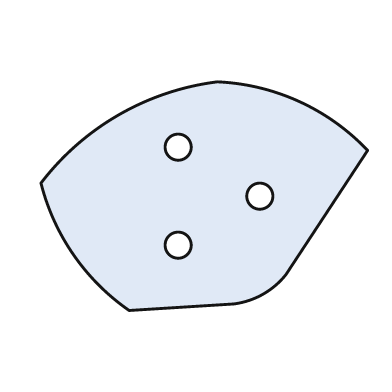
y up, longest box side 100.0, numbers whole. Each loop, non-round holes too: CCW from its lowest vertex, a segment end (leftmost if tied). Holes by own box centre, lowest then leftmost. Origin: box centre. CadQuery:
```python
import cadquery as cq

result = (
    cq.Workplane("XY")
    .moveTo(-23.0, -35.0)
    .lineTo(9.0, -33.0)
    .threePointArc((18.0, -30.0), (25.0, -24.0))
    .lineTo(50.0, 14.0)
    .threePointArc((29.0, 29.0), (4.0, 35.0))
    .threePointArc((-26.0, 25.0), (-50.0, 4.0))
    .threePointArc((-40.0, -18.0), (-23.0, -35.0))
    .close()
    .moveTo(-8.0, -15.0)
    .circle(4.0)
    .moveTo(17.0, 0.0)
    .circle(4.0)
    .moveTo(-8.0, 15.0)
    .circle(4.0)
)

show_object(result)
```